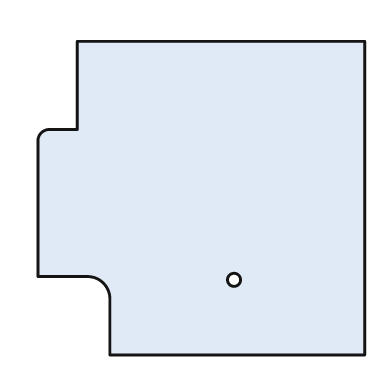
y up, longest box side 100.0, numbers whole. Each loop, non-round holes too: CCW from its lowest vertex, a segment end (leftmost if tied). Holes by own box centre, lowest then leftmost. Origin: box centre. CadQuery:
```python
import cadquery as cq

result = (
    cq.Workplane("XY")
    .moveTo(-28.0, -48.0)
    .lineTo(50.0, -48.0)
    .lineTo(50.0, 48.0)
    .lineTo(-38.0, 48.0)
    .lineTo(-38.0, 21.0)
    .lineTo(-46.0, 21.0)
    .threePointArc((-49.0, 20.0), (-50.0, 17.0))
    .lineTo(-50.0, -24.0)
    .lineTo(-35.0, -24.0)
    .threePointArc((-30.0, -26.0), (-28.0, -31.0))
    .close()
    .moveTo(10.0, -25.0)
    .circle(2.0)
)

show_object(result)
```